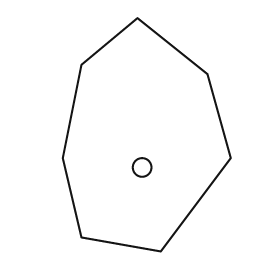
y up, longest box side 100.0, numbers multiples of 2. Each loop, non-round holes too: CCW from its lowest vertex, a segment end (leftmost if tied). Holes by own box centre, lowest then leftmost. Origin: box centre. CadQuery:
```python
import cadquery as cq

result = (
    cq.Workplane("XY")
    .moveTo(6.0, -50.0)
    .lineTo(36.0, -10.0)
    .lineTo(26.0, 26.0)
    .lineTo(-4.0, 50.0)
    .lineTo(-28.0, 30.0)
    .lineTo(-36.0, -10.0)
    .lineTo(-28.0, -44.0)
    .close()
    .moveTo(-2.0, -14.0)
    .circle(4.0)
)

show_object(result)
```